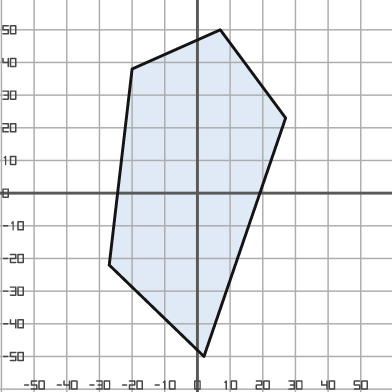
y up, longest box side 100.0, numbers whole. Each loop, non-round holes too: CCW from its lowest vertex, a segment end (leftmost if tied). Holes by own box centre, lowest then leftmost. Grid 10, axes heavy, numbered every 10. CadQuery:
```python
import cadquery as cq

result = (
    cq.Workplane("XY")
    .moveTo(2.0, -50.0)
    .lineTo(27.0, 23.0)
    .lineTo(7.0, 50.0)
    .lineTo(-20.0, 38.0)
    .lineTo(-27.0, -22.0)
    .close()
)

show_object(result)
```